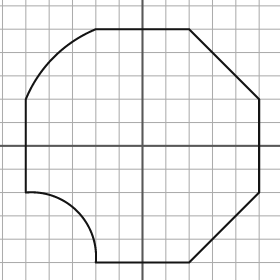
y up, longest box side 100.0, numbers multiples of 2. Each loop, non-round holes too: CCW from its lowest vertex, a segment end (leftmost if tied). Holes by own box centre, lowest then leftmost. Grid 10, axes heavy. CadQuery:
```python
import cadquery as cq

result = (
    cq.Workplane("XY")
    .moveTo(-20.0, -50.0)
    .lineTo(20.0, -50.0)
    .lineTo(50.0, -20.0)
    .lineTo(50.0, 20.0)
    .lineTo(20.0, 50.0)
    .lineTo(-20.0, 50.0)
    .threePointArc((-38.0, 38.0), (-50.0, 20.0))
    .lineTo(-50.0, -20.0)
    .threePointArc((-28.0, -28.0), (-20.0, -50.0))
    .close()
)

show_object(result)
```